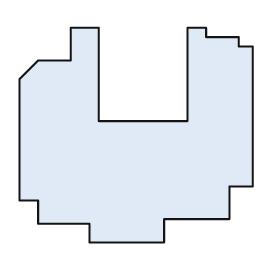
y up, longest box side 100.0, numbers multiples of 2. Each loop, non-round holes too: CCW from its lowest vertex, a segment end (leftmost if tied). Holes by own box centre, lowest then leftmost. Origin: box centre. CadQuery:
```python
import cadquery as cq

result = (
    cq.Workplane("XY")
    .moveTo(-20.0, -46.0)
    .lineTo(12.0, -46.0)
    .lineTo(12.0, -36.0)
    .lineTo(40.0, -36.0)
    .lineTo(40.0, -22.0)
    .lineTo(50.0, -22.0)
    .lineTo(50.0, 38.0)
    .lineTo(44.0, 38.0)
    .lineTo(44.0, 42.0)
    .lineTo(30.0, 42.0)
    .lineTo(30.0, 46.0)
    .lineTo(22.0, 46.0)
    .lineTo(22.0, 6.0)
    .lineTo(-16.0, 6.0)
    .lineTo(-16.0, 46.0)
    .lineTo(-28.0, 46.0)
    .lineTo(-28.0, 32.0)
    .lineTo(-42.0, 32.0)
    .lineTo(-50.0, 24.0)
    .lineTo(-50.0, -28.0)
    .lineTo(-42.0, -28.0)
    .lineTo(-42.0, -38.0)
    .lineTo(-20.0, -38.0)
    .close()
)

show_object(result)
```